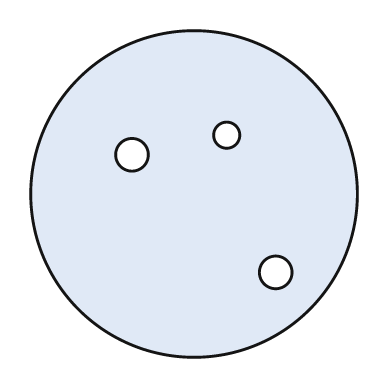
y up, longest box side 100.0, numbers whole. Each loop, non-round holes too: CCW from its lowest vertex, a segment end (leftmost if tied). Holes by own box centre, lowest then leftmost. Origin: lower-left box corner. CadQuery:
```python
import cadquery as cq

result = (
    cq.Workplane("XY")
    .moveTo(50.0, 50.0)
    .circle(50.0)
    .moveTo(75.0, 26.0)
    .circle(5.0)
    .moveTo(31.0, 62.0)
    .circle(5.0)
    .moveTo(60.0, 68.0)
    .circle(4.0)
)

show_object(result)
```